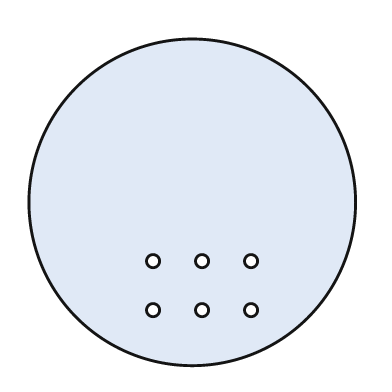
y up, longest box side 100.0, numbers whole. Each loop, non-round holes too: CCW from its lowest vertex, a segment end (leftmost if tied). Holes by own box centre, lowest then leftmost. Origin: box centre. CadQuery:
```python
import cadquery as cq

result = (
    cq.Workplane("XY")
    .moveTo(0.0, 0.0)
    .circle(50.0)
    .moveTo(-12.0, -33.0)
    .circle(2.0)
    .moveTo(3.0, -33.0)
    .circle(2.0)
    .moveTo(18.0, -33.0)
    .circle(2.0)
    .moveTo(-12.0, -18.0)
    .circle(2.0)
    .moveTo(3.0, -18.0)
    .circle(2.0)
    .moveTo(18.0, -18.0)
    .circle(2.0)
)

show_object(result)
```